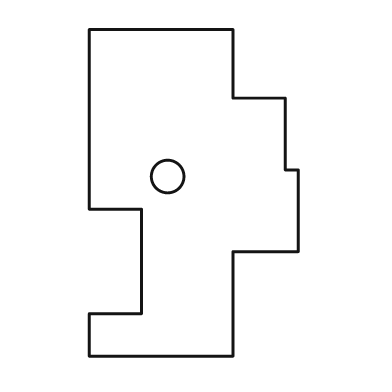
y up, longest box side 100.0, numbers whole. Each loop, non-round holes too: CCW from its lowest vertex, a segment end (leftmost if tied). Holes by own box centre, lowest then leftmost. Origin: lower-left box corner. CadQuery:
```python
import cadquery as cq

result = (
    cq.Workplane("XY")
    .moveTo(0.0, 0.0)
    .lineTo(44.0, 0.0)
    .lineTo(44.0, 32.0)
    .lineTo(64.0, 32.0)
    .lineTo(64.0, 57.0)
    .lineTo(60.0, 57.0)
    .lineTo(60.0, 79.0)
    .lineTo(44.0, 79.0)
    .lineTo(44.0, 100.0)
    .lineTo(0.0, 100.0)
    .lineTo(0.0, 45.0)
    .lineTo(16.0, 45.0)
    .lineTo(16.0, 13.0)
    .lineTo(0.0, 13.0)
    .close()
    .moveTo(24.0, 55.0)
    .circle(5.0)
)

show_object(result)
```